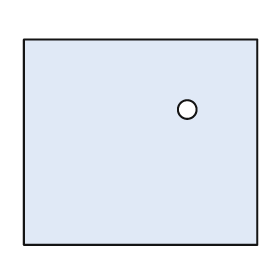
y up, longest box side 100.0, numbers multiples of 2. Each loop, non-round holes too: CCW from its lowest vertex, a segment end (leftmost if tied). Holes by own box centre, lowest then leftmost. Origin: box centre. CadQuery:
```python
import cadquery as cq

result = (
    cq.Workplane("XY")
    .moveTo(-50.0, -44.0)
    .lineTo(50.0, -44.0)
    .lineTo(50.0, 44.0)
    .lineTo(-50.0, 44.0)
    .close()
    .moveTo(20.0, 14.0)
    .circle(4.0)
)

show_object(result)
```